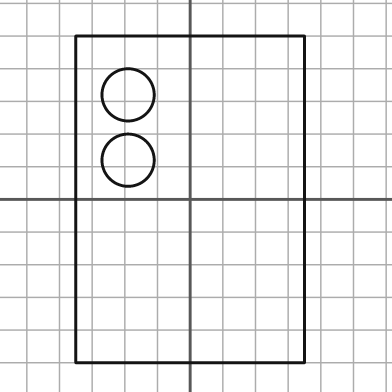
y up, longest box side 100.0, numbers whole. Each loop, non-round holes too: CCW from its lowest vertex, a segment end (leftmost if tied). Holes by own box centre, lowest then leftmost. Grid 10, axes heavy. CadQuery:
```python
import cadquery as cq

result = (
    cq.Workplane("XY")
    .moveTo(-35.0, -50.0)
    .lineTo(35.0, -50.0)
    .lineTo(35.0, 50.0)
    .lineTo(-35.0, 50.0)
    .close()
    .moveTo(-19.0, 12.0)
    .circle(8.0)
    .moveTo(-19.0, 32.0)
    .circle(8.0)
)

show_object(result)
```